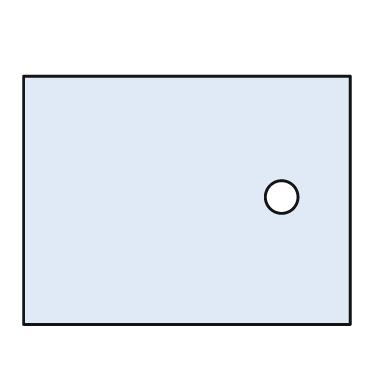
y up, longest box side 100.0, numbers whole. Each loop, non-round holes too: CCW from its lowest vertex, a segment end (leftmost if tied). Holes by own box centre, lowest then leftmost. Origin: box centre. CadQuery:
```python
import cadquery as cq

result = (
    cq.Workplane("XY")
    .moveTo(-50.0, -38.0)
    .lineTo(50.0, -38.0)
    .lineTo(50.0, 38.0)
    .lineTo(-50.0, 38.0)
    .close()
    .moveTo(29.0, 1.0)
    .circle(5.0)
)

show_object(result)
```